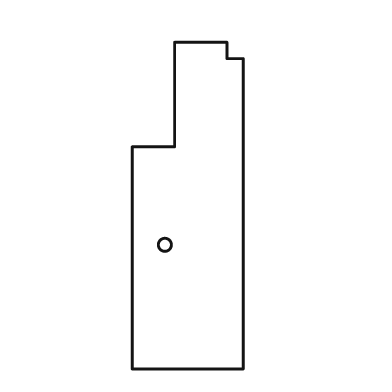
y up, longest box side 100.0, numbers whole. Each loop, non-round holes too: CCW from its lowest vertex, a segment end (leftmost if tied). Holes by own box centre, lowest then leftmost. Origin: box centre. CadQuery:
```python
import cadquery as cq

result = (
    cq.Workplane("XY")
    .moveTo(-17.0, -50.0)
    .lineTo(17.0, -50.0)
    .lineTo(17.0, 45.0)
    .lineTo(12.0, 45.0)
    .lineTo(12.0, 50.0)
    .lineTo(-4.0, 50.0)
    .lineTo(-4.0, 18.0)
    .lineTo(-17.0, 18.0)
    .close()
    .moveTo(-7.0, -12.0)
    .circle(2.0)
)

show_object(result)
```